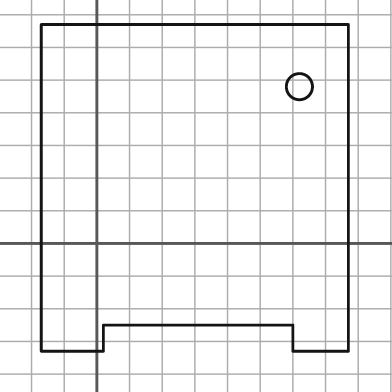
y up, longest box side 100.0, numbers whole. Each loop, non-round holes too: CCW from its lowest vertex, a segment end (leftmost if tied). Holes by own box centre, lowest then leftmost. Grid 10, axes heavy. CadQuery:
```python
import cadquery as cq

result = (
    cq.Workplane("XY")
    .moveTo(-17.0, -33.0)
    .lineTo(2.0, -33.0)
    .lineTo(2.0, -25.0)
    .lineTo(60.0, -25.0)
    .lineTo(60.0, -33.0)
    .lineTo(77.0, -33.0)
    .lineTo(77.0, 67.0)
    .lineTo(-17.0, 67.0)
    .close()
    .moveTo(62.0, 48.0)
    .circle(4.0)
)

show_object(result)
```